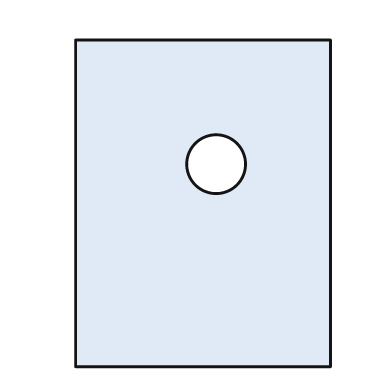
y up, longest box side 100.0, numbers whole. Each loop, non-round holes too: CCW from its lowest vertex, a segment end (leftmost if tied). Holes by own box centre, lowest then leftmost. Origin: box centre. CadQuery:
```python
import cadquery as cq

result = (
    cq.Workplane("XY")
    .moveTo(-39.0, -50.0)
    .lineTo(39.0, -50.0)
    .lineTo(39.0, 50.0)
    .lineTo(-39.0, 50.0)
    .close()
    .moveTo(4.0, 12.0)
    .circle(9.0)
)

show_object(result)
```